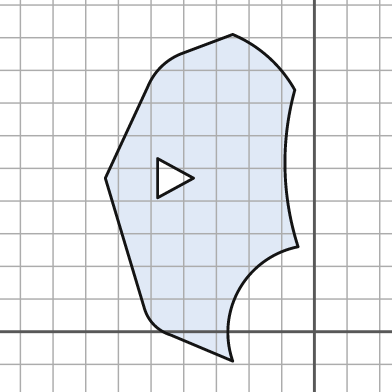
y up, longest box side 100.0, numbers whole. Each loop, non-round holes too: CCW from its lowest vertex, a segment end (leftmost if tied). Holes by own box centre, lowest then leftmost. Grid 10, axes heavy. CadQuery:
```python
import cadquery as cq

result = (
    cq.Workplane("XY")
    .moveTo(-25.0, -9.0)
    .threePointArc((-23.0, 13.0), (-5.0, 26.0))
    .threePointArc((-9.0, 50.0), (-6.0, 74.0))
    .threePointArc((-14.0, 84.0), (-25.0, 91.0))
    .lineTo(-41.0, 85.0)
    .threePointArc((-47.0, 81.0), (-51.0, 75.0))
    .lineTo(-64.0, 47.0)
    .lineTo(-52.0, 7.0)
    .threePointArc((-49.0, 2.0), (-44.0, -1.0))
    .close()
    .moveTo(-48.0, 41.0)
    .lineTo(-37.0, 47.0)
    .lineTo(-48.0, 53.0)
    .close()
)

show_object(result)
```